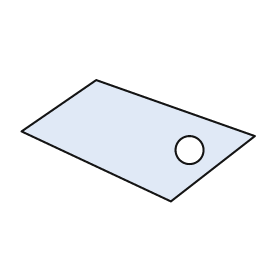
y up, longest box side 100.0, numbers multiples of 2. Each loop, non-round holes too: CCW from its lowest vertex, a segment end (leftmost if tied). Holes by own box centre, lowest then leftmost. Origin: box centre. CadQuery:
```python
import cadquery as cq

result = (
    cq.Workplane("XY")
    .moveTo(14.0, -26.0)
    .lineTo(50.0, 2.0)
    .lineTo(-18.0, 26.0)
    .lineTo(-50.0, 4.0)
    .close()
    .moveTo(22.0, -4.0)
    .circle(6.0)
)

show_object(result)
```